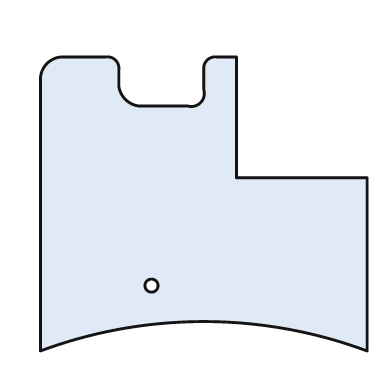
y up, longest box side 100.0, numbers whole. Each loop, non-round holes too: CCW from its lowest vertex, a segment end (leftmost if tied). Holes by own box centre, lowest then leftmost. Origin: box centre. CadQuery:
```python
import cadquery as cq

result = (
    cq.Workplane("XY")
    .moveTo(-50.0, -45.0)
    .threePointArc((0.0, -36.0), (50.0, -45.0))
    .lineTo(50.0, 8.0)
    .lineTo(10.0, 8.0)
    .lineTo(10.0, 45.0)
    .lineTo(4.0, 45.0)
    .threePointArc((1.0, 44.0), (0.0, 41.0))
    .lineTo(0.0, 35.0)
    .threePointArc((-1.0, 31.0), (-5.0, 30.0))
    .lineTo(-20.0, 30.0)
    .threePointArc((-24.0, 32.0), (-26.0, 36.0))
    .lineTo(-26.0, 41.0)
    .threePointArc((-27.0, 44.0), (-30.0, 45.0))
    .lineTo(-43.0, 45.0)
    .threePointArc((-48.0, 43.0), (-50.0, 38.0))
    .close()
    .moveTo(-16.0, -25.0)
    .circle(2.0)
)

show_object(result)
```